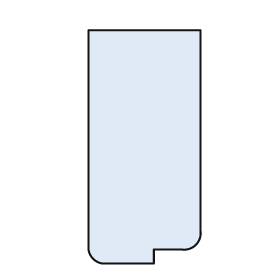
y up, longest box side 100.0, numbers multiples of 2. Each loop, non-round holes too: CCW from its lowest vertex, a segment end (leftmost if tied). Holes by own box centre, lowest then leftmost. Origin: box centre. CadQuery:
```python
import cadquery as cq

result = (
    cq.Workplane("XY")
    .moveTo(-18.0, -50.0)
    .lineTo(4.0, -50.0)
    .lineTo(4.0, -44.0)
    .lineTo(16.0, -44.0)
    .threePointArc((22.0, -42.0), (24.0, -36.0))
    .lineTo(24.0, 50.0)
    .lineTo(-24.0, 50.0)
    .lineTo(-24.0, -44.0)
    .threePointArc((-22.0, -48.0), (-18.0, -50.0))
    .close()
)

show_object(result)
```